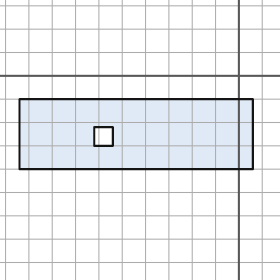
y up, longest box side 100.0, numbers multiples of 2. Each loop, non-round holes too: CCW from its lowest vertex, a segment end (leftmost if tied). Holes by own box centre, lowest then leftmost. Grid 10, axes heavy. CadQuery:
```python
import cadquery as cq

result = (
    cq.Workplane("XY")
    .moveTo(-94.0, -40.0)
    .lineTo(6.0, -40.0)
    .lineTo(6.0, -10.0)
    .lineTo(-94.0, -10.0)
    .close()
    .moveTo(-62.0, -30.0)
    .lineTo(-54.0, -30.0)
    .lineTo(-54.0, -22.0)
    .lineTo(-62.0, -22.0)
    .close()
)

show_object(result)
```